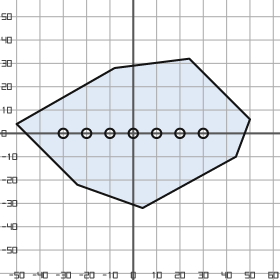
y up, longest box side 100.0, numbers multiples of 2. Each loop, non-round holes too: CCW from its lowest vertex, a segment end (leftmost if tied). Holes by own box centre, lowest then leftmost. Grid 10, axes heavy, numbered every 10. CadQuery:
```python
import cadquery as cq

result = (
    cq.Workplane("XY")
    .moveTo(4.0, -32.0)
    .lineTo(44.0, -10.0)
    .lineTo(50.0, 6.0)
    .lineTo(24.0, 32.0)
    .lineTo(-8.0, 28.0)
    .lineTo(-50.0, 4.0)
    .lineTo(-24.0, -22.0)
    .close()
    .moveTo(-30.0, 0.0)
    .circle(2.0)
    .moveTo(-20.0, 0.0)
    .circle(2.0)
    .moveTo(-10.0, 0.0)
    .circle(2.0)
    .moveTo(0.0, 0.0)
    .circle(2.0)
    .moveTo(10.0, 0.0)
    .circle(2.0)
    .moveTo(20.0, 0.0)
    .circle(2.0)
    .moveTo(30.0, 0.0)
    .circle(2.0)
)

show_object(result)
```